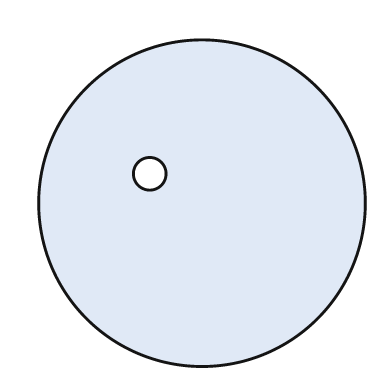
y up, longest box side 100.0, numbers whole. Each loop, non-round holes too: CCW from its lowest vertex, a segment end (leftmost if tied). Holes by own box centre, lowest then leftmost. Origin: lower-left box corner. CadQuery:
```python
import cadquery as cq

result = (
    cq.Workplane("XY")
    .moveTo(50.0, 50.0)
    .circle(50.0)
    .moveTo(34.0, 59.0)
    .circle(5.0)
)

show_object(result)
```